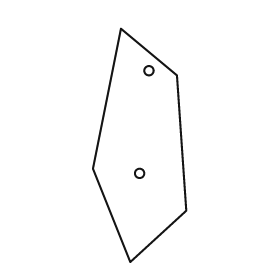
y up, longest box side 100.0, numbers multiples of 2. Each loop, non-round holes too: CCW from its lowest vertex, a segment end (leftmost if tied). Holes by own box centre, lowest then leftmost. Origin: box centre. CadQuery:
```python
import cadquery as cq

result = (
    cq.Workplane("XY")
    .moveTo(-4.0, -50.0)
    .lineTo(20.0, -28.0)
    .lineTo(16.0, 30.0)
    .lineTo(-8.0, 50.0)
    .lineTo(-20.0, -10.0)
    .close()
    .moveTo(0.0, -12.0)
    .circle(2.0)
    .moveTo(4.0, 32.0)
    .circle(2.0)
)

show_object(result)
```